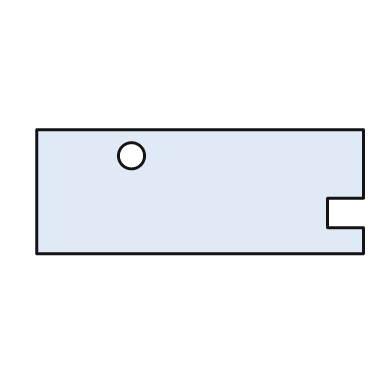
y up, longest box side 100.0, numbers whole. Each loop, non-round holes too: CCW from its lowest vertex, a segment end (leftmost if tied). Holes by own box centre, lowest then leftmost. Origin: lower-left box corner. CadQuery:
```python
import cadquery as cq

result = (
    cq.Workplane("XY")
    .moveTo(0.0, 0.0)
    .lineTo(100.0, 0.0)
    .lineTo(100.0, 8.0)
    .lineTo(89.0, 8.0)
    .lineTo(89.0, 17.0)
    .lineTo(100.0, 17.0)
    .lineTo(100.0, 38.0)
    .lineTo(0.0, 38.0)
    .close()
    .moveTo(29.0, 30.0)
    .circle(4.0)
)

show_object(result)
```